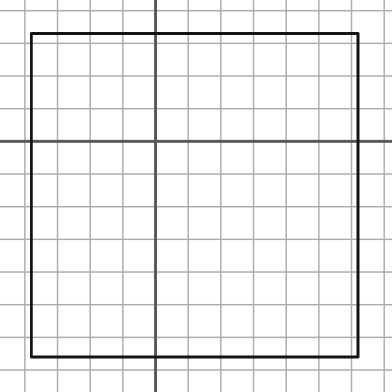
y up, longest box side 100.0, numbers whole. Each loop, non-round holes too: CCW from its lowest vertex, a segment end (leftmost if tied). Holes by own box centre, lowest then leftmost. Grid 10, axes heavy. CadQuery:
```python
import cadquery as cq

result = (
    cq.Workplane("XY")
    .moveTo(-38.0, -66.0)
    .lineTo(62.0, -66.0)
    .lineTo(62.0, 33.0)
    .lineTo(-38.0, 33.0)
    .close()
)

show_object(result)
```